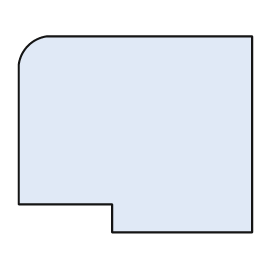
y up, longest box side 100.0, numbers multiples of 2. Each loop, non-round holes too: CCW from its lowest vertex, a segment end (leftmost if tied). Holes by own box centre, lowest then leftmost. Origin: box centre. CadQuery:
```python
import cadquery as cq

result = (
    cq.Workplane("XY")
    .moveTo(-10.0, -42.0)
    .lineTo(50.0, -42.0)
    .lineTo(50.0, 42.0)
    .lineTo(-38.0, 42.0)
    .threePointArc((-46.0, 38.0), (-50.0, 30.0))
    .lineTo(-50.0, -30.0)
    .lineTo(-10.0, -30.0)
    .close()
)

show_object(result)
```